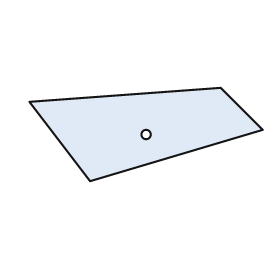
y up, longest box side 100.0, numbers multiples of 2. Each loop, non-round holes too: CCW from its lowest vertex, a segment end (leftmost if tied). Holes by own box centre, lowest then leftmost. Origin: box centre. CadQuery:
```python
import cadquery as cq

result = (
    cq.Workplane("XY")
    .moveTo(-24.0, -20.0)
    .lineTo(50.0, 2.0)
    .lineTo(32.0, 20.0)
    .lineTo(-50.0, 14.0)
    .close()
    .moveTo(0.0, 0.0)
    .circle(2.0)
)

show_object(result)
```